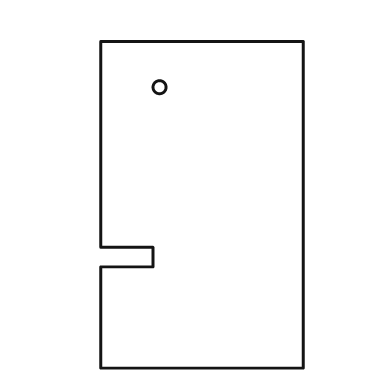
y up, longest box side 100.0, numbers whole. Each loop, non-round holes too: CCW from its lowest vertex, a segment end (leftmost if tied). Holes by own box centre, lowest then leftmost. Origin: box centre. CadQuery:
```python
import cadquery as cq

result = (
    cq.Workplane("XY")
    .moveTo(-31.0, -50.0)
    .lineTo(31.0, -50.0)
    .lineTo(31.0, 50.0)
    .lineTo(-31.0, 50.0)
    .lineTo(-31.0, -13.0)
    .lineTo(-15.0, -13.0)
    .lineTo(-15.0, -19.0)
    .lineTo(-31.0, -19.0)
    .close()
    .moveTo(-13.0, 36.0)
    .circle(2.0)
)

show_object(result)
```